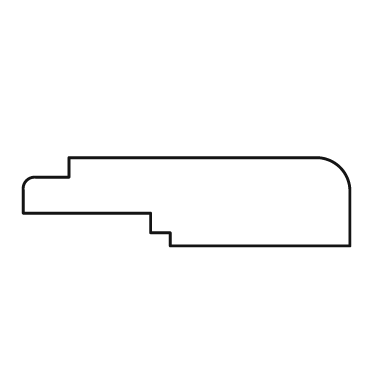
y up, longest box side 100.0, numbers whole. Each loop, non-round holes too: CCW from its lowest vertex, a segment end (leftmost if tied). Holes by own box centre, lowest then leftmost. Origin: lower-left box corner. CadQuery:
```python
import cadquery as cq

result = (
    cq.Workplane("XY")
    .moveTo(45.0, 0.0)
    .lineTo(100.0, 0.0)
    .lineTo(100.0, 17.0)
    .threePointArc((97.0, 24.0), (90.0, 27.0))
    .lineTo(14.0, 27.0)
    .lineTo(14.0, 21.0)
    .lineTo(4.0, 21.0)
    .threePointArc((1.0, 20.0), (0.0, 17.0))
    .lineTo(0.0, 10.0)
    .lineTo(39.0, 10.0)
    .lineTo(39.0, 4.0)
    .lineTo(45.0, 4.0)
    .close()
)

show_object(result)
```